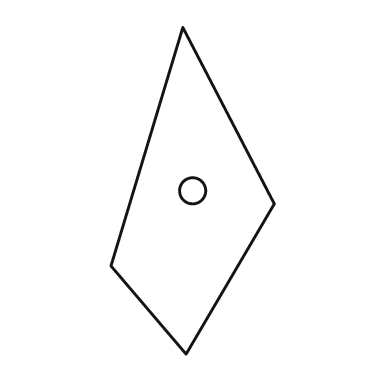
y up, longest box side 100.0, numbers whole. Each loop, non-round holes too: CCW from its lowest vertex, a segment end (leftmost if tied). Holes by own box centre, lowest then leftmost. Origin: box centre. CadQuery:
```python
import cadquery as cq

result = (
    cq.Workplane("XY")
    .moveTo(-2.0, -50.0)
    .lineTo(25.0, -4.0)
    .lineTo(-3.0, 50.0)
    .lineTo(-25.0, -23.0)
    .close()
    .moveTo(0.0, 0.0)
    .circle(4.0)
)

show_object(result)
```